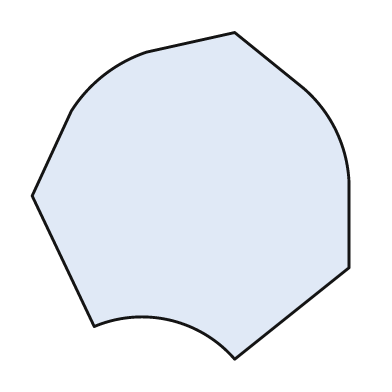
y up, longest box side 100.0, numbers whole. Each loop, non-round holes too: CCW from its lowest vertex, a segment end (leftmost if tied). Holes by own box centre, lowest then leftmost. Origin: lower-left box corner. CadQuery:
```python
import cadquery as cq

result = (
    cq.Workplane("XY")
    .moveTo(62.0, 0.0)
    .lineTo(97.0, 28.0)
    .lineTo(97.0, 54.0)
    .threePointArc((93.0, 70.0), (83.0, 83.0))
    .lineTo(62.0, 100.0)
    .lineTo(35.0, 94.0)
    .threePointArc((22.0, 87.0), (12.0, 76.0))
    .lineTo(0.0, 50.0)
    .lineTo(19.0, 10.0)
    .threePointArc((42.0, 12.0), (62.0, 0.0))
    .close()
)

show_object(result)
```